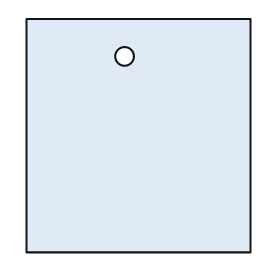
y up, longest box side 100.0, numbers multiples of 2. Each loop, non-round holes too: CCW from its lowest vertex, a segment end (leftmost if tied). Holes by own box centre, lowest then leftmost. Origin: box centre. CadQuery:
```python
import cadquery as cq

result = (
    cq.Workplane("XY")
    .moveTo(-48.0, -50.0)
    .lineTo(48.0, -50.0)
    .lineTo(48.0, 50.0)
    .lineTo(-48.0, 50.0)
    .close()
    .moveTo(-6.0, 34.0)
    .circle(4.0)
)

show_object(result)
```